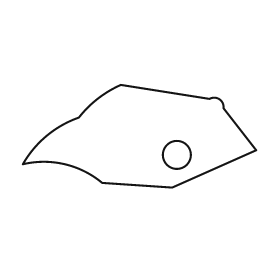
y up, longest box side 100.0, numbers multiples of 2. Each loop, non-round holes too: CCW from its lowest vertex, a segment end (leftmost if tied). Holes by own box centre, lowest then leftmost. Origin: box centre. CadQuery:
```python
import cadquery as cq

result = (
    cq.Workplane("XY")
    .moveTo(14.0, -22.0)
    .lineTo(50.0, -6.0)
    .lineTo(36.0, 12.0)
    .threePointArc((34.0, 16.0), (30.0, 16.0))
    .lineTo(-8.0, 22.0)
    .threePointArc((-18.0, 16.0), (-26.0, 8.0))
    .threePointArc((-40.0, 0.0), (-50.0, -12.0))
    .threePointArc((-32.0, -12.0), (-16.0, -20.0))
    .close()
    .moveTo(16.0, -8.0)
    .circle(6.0)
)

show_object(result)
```